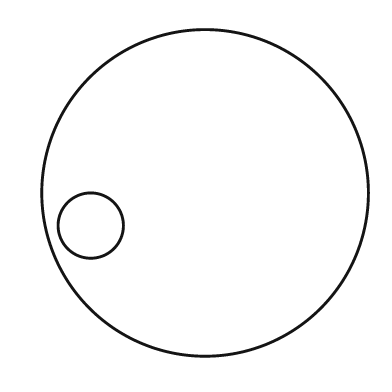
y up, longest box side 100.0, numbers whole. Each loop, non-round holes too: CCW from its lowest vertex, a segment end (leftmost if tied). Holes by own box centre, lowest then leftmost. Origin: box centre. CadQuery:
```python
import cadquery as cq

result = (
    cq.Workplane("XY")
    .moveTo(0.0, 0.0)
    .circle(50.0)
    .moveTo(-35.0, -10.0)
    .circle(10.0)
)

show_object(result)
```